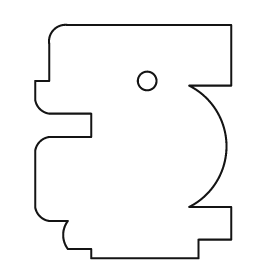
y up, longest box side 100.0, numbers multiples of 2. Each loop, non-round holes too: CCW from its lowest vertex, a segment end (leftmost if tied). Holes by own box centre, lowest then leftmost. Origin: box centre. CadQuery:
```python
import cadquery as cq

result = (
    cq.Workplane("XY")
    .moveTo(-18.0, -50.0)
    .lineTo(28.0, -50.0)
    .lineTo(28.0, -42.0)
    .lineTo(42.0, -42.0)
    .lineTo(42.0, -28.0)
    .lineTo(24.0, -28.0)
    .threePointArc((40.0, -2.0), (24.0, 24.0))
    .lineTo(42.0, 24.0)
    .lineTo(42.0, 50.0)
    .lineTo(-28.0, 50.0)
    .threePointArc((-34.0, 48.0), (-36.0, 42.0))
    .lineTo(-36.0, 26.0)
    .lineTo(-42.0, 26.0)
    .lineTo(-42.0, 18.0)
    .threePointArc((-40.0, 14.0), (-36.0, 12.0))
    .lineTo(-18.0, 12.0)
    .lineTo(-18.0, 2.0)
    .lineTo(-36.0, 2.0)
    .threePointArc((-40.0, 0.0), (-42.0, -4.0))
    .lineTo(-42.0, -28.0)
    .threePointArc((-40.0, -32.0), (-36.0, -34.0))
    .lineTo(-28.0, -34.0)
    .threePointArc((-30.0, -40.0), (-28.0, -46.0))
    .lineTo(-18.0, -46.0)
    .close()
    .moveTo(6.0, 26.0)
    .circle(4.0)
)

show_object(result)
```